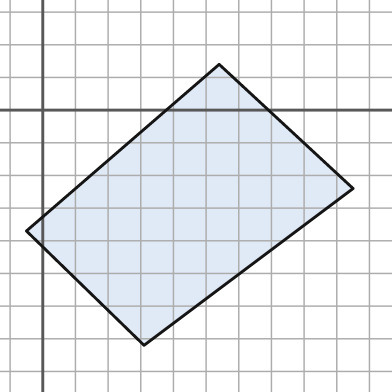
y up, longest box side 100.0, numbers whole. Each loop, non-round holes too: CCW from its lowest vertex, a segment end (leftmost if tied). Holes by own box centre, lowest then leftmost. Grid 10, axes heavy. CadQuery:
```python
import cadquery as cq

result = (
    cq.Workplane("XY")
    .moveTo(31.0, -72.0)
    .lineTo(95.0, -24.0)
    .lineTo(54.0, 14.0)
    .lineTo(-5.0, -37.0)
    .close()
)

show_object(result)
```